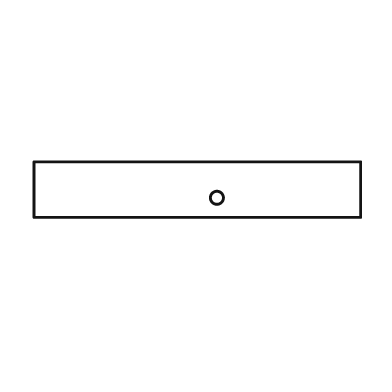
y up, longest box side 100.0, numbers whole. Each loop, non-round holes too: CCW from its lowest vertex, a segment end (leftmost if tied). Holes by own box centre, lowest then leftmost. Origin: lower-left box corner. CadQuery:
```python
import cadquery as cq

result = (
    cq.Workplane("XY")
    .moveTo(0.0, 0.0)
    .lineTo(100.0, 0.0)
    .lineTo(100.0, 17.0)
    .lineTo(0.0, 17.0)
    .close()
    .moveTo(56.0, 6.0)
    .circle(2.0)
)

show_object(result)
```